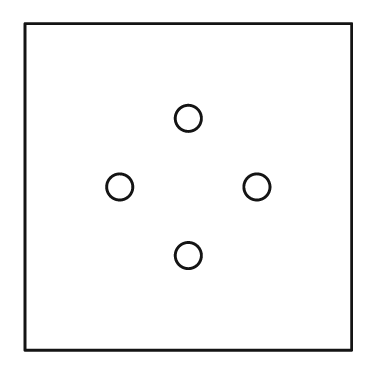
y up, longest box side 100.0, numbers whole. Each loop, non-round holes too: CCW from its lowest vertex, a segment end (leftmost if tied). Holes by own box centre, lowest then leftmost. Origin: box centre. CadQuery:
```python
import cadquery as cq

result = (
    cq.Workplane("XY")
    .moveTo(-50.0, -50.0)
    .lineTo(50.0, -50.0)
    .lineTo(50.0, 50.0)
    .lineTo(-50.0, 50.0)
    .close()
    .moveTo(0.0, -21.0)
    .circle(4.0)
    .moveTo(-21.0, 0.0)
    .circle(4.0)
    .moveTo(21.0, 0.0)
    .circle(4.0)
    .moveTo(0.0, 21.0)
    .circle(4.0)
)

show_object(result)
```